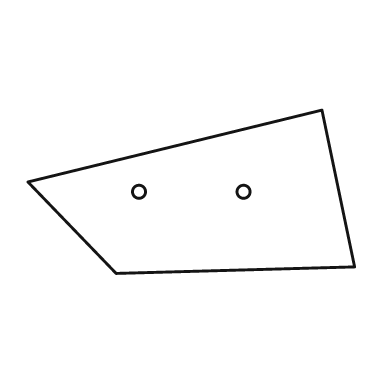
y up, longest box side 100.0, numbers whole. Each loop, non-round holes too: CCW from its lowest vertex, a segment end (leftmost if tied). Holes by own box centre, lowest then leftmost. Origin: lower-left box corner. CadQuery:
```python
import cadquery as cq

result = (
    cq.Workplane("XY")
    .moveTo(27.0, 0.0)
    .lineTo(100.0, 2.0)
    .lineTo(90.0, 50.0)
    .lineTo(0.0, 28.0)
    .close()
    .moveTo(34.0, 25.0)
    .circle(2.0)
    .moveTo(66.0, 25.0)
    .circle(2.0)
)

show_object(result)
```